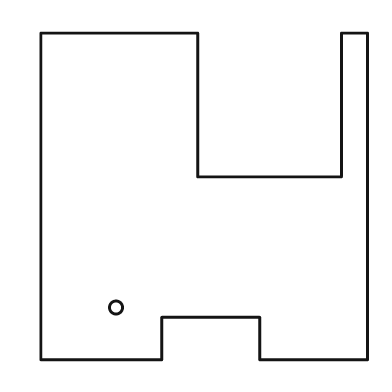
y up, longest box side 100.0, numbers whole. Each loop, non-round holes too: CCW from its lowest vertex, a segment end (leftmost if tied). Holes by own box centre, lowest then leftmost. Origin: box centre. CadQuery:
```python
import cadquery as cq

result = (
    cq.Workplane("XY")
    .moveTo(-50.0, -50.0)
    .lineTo(-13.0, -50.0)
    .lineTo(-13.0, -37.0)
    .lineTo(17.0, -37.0)
    .lineTo(17.0, -50.0)
    .lineTo(50.0, -50.0)
    .lineTo(50.0, 50.0)
    .lineTo(42.0, 50.0)
    .lineTo(42.0, 6.0)
    .lineTo(-2.0, 6.0)
    .lineTo(-2.0, 50.0)
    .lineTo(-50.0, 50.0)
    .close()
    .moveTo(-27.0, -34.0)
    .circle(2.0)
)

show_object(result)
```